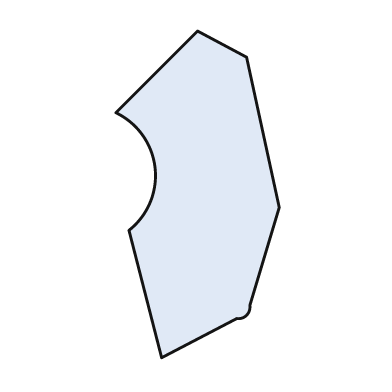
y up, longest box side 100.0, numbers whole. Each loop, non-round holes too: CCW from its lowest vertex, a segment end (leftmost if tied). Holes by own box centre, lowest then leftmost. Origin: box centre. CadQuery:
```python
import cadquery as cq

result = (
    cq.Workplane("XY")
    .moveTo(-11.0, -50.0)
    .lineTo(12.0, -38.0)
    .threePointArc((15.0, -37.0), (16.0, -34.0))
    .lineTo(25.0, -4.0)
    .lineTo(15.0, 42.0)
    .lineTo(0.0, 50.0)
    .lineTo(-25.0, 25.0)
    .threePointArc((-13.0, 8.0), (-21.0, -11.0))
    .close()
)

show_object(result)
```